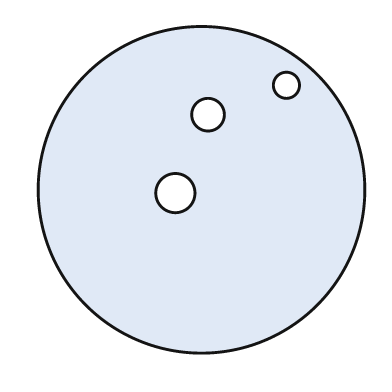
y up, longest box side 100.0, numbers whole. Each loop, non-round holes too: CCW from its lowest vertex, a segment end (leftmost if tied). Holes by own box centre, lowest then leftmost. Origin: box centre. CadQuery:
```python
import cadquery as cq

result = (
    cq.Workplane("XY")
    .moveTo(0.0, 0.0)
    .circle(50.0)
    .moveTo(-8.0, -1.0)
    .circle(6.0)
    .moveTo(2.0, 23.0)
    .circle(5.0)
    .moveTo(26.0, 32.0)
    .circle(4.0)
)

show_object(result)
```